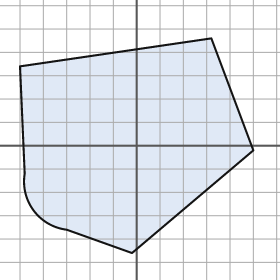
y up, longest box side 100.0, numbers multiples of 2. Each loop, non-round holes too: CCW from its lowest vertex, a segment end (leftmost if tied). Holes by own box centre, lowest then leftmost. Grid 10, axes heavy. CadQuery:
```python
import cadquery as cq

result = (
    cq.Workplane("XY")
    .moveTo(-2.0, -46.0)
    .lineTo(50.0, -2.0)
    .lineTo(32.0, 46.0)
    .lineTo(-50.0, 34.0)
    .lineTo(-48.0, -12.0)
    .threePointArc((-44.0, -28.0), (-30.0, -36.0))
    .close()
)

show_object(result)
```